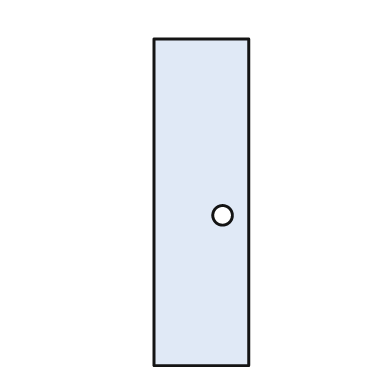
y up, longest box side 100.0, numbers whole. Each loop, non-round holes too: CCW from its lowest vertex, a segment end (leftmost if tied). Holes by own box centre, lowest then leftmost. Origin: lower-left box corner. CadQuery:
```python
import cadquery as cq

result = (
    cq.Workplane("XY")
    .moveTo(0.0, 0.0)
    .lineTo(29.0, 0.0)
    .lineTo(29.0, 100.0)
    .lineTo(0.0, 100.0)
    .close()
    .moveTo(21.0, 46.0)
    .circle(3.0)
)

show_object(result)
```